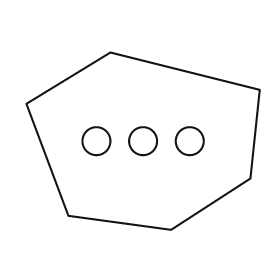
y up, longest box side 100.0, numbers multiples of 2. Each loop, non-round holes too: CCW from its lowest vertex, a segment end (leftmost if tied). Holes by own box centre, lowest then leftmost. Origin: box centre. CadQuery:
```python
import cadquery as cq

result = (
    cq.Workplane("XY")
    .moveTo(12.0, -38.0)
    .lineTo(46.0, -16.0)
    .lineTo(50.0, 22.0)
    .lineTo(-14.0, 38.0)
    .lineTo(-50.0, 16.0)
    .lineTo(-32.0, -32.0)
    .close()
    .moveTo(-20.0, 0.0)
    .circle(6.0)
    .moveTo(0.0, 0.0)
    .circle(6.0)
    .moveTo(20.0, 0.0)
    .circle(6.0)
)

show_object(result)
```